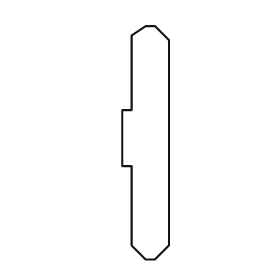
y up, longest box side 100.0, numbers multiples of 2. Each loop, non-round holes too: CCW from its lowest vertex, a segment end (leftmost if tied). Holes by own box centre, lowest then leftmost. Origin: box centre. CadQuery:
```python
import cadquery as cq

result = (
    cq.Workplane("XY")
    .moveTo(0.0, -50.0)
    .lineTo(4.0, -50.0)
    .lineTo(10.0, -44.0)
    .lineTo(10.0, 44.0)
    .lineTo(4.0, 50.0)
    .lineTo(0.0, 50.0)
    .lineTo(-6.0, 46.0)
    .lineTo(-6.0, 14.0)
    .lineTo(-10.0, 14.0)
    .lineTo(-10.0, -10.0)
    .lineTo(-6.0, -10.0)
    .lineTo(-6.0, -44.0)
    .close()
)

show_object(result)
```